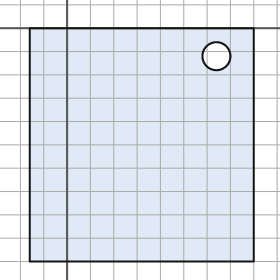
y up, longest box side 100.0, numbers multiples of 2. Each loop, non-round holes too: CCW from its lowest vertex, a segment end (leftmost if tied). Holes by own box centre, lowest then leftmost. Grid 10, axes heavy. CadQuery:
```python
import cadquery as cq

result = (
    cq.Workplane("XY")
    .moveTo(-16.0, -100.0)
    .lineTo(80.0, -100.0)
    .lineTo(80.0, 0.0)
    .lineTo(-16.0, 0.0)
    .close()
    .moveTo(64.0, -12.0)
    .circle(6.0)
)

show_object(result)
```